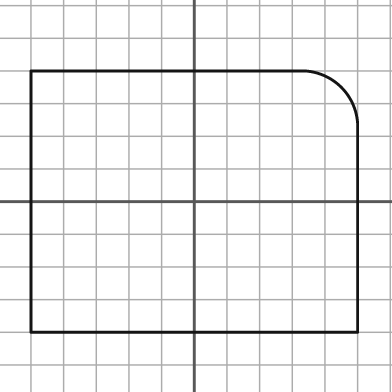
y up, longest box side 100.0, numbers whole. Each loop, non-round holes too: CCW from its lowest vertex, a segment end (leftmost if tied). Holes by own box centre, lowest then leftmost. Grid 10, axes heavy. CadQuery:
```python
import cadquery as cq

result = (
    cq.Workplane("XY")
    .moveTo(-50.0, -40.0)
    .lineTo(50.0, -40.0)
    .lineTo(50.0, 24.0)
    .threePointArc((45.0, 35.0), (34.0, 40.0))
    .lineTo(-50.0, 40.0)
    .close()
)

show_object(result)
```